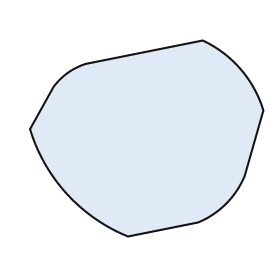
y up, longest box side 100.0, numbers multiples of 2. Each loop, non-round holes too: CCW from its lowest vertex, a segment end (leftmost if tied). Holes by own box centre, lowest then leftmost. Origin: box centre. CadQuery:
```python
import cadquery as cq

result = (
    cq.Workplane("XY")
    .moveTo(-8.0, -42.0)
    .lineTo(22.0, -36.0)
    .threePointArc((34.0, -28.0), (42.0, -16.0))
    .lineTo(50.0, 12.0)
    .threePointArc((40.0, 30.0), (24.0, 42.0))
    .lineTo(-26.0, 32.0)
    .threePointArc((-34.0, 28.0), (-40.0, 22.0))
    .lineTo(-50.0, 4.0)
    .threePointArc((-34.0, -24.0), (-8.0, -42.0))
    .close()
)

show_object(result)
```